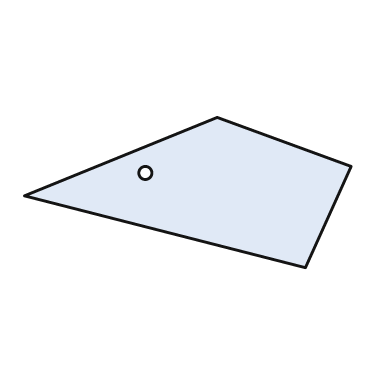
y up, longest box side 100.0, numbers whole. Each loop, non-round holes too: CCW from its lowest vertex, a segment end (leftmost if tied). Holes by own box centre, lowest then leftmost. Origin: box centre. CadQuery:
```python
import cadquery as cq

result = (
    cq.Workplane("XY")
    .moveTo(36.0, -23.0)
    .lineTo(50.0, 8.0)
    .lineTo(9.0, 23.0)
    .lineTo(-50.0, -1.0)
    .close()
    .moveTo(-13.0, 6.0)
    .circle(2.0)
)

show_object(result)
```